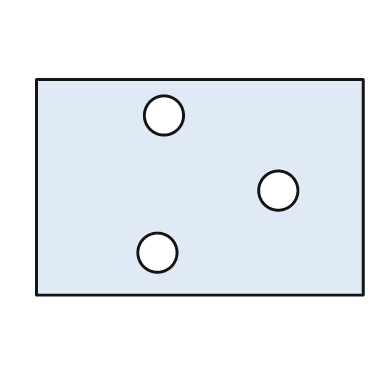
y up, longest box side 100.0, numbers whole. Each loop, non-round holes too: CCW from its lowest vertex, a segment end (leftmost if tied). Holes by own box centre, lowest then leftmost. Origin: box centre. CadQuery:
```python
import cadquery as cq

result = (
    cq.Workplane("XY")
    .moveTo(-50.0, -33.0)
    .lineTo(50.0, -33.0)
    .lineTo(50.0, 33.0)
    .lineTo(-50.0, 33.0)
    .close()
    .moveTo(-13.0, -20.0)
    .circle(6.0)
    .moveTo(24.0, -1.0)
    .circle(6.0)
    .moveTo(-11.0, 22.0)
    .circle(6.0)
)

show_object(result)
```